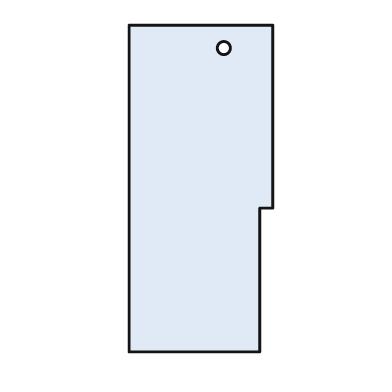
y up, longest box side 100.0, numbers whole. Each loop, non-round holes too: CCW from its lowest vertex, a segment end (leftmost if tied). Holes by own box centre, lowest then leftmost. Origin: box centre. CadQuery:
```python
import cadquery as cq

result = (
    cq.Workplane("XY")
    .moveTo(-22.0, -50.0)
    .lineTo(18.0, -50.0)
    .lineTo(18.0, -6.0)
    .lineTo(22.0, -6.0)
    .lineTo(22.0, 50.0)
    .lineTo(-22.0, 50.0)
    .close()
    .moveTo(7.0, 43.0)
    .circle(2.0)
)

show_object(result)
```